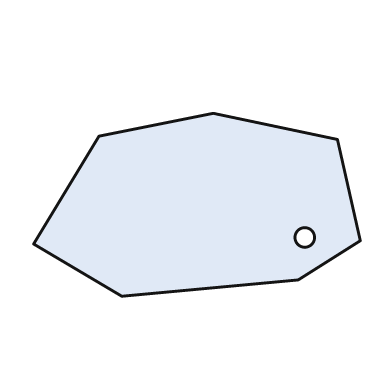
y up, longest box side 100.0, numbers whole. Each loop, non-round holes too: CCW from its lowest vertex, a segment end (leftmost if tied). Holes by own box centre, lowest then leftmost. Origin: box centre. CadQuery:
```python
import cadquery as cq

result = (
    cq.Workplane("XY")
    .moveTo(-23.0, -28.0)
    .lineTo(31.0, -23.0)
    .lineTo(50.0, -11.0)
    .lineTo(43.0, 20.0)
    .lineTo(5.0, 28.0)
    .lineTo(-30.0, 21.0)
    .lineTo(-50.0, -12.0)
    .close()
    .moveTo(33.0, -10.0)
    .circle(3.0)
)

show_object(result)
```